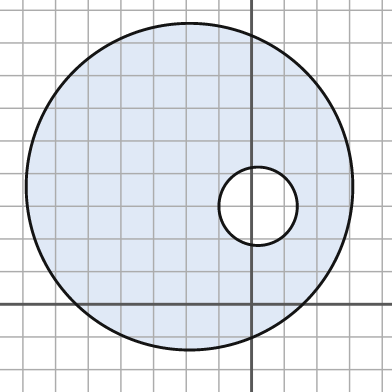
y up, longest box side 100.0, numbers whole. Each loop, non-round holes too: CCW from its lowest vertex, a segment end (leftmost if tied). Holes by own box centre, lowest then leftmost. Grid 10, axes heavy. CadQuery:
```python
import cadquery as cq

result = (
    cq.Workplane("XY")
    .moveTo(-19.0, 36.0)
    .circle(50.0)
    .moveTo(2.0, 30.0)
    .circle(12.0)
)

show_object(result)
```